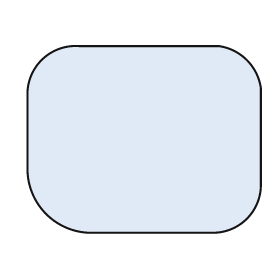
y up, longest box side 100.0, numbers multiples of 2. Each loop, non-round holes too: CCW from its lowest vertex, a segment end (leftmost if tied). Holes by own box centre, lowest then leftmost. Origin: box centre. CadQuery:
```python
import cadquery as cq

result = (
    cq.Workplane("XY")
    .moveTo(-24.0, -40.0)
    .lineTo(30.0, -40.0)
    .threePointArc((44.0, -34.0), (50.0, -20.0))
    .lineTo(50.0, 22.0)
    .threePointArc((44.0, 34.0), (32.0, 40.0))
    .lineTo(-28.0, 40.0)
    .threePointArc((-44.0, 34.0), (-50.0, 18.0))
    .lineTo(-50.0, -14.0)
    .threePointArc((-42.0, -32.0), (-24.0, -40.0))
    .close()
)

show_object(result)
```